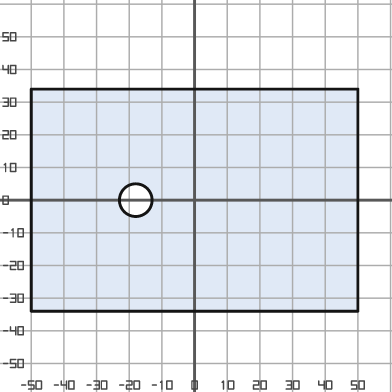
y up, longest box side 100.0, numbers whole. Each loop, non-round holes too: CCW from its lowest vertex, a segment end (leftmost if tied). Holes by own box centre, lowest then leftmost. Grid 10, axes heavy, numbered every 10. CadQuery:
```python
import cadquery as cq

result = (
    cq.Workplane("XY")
    .moveTo(-50.0, -34.0)
    .lineTo(50.0, -34.0)
    .lineTo(50.0, 34.0)
    .lineTo(-50.0, 34.0)
    .close()
    .moveTo(-18.0, 0.0)
    .circle(5.0)
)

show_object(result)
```